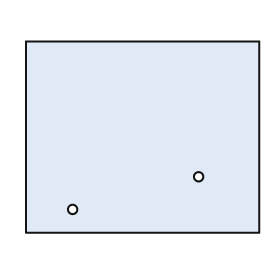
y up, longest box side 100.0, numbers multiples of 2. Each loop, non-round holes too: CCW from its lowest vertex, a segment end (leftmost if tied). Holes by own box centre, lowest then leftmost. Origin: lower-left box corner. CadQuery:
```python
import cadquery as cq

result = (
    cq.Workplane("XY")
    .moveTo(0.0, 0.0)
    .lineTo(100.0, 0.0)
    .lineTo(100.0, 82.0)
    .lineTo(0.0, 82.0)
    .close()
    .moveTo(20.0, 10.0)
    .circle(2.0)
    .moveTo(74.0, 24.0)
    .circle(2.0)
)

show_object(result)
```